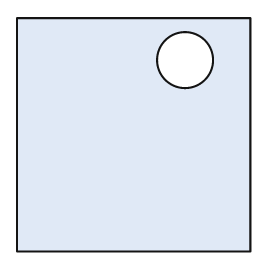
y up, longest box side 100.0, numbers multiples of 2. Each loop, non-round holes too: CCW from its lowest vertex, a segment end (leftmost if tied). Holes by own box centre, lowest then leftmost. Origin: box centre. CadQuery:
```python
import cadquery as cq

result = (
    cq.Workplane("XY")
    .moveTo(-50.0, -50.0)
    .lineTo(50.0, -50.0)
    .lineTo(50.0, 50.0)
    .lineTo(-50.0, 50.0)
    .close()
    .moveTo(22.0, 32.0)
    .circle(12.0)
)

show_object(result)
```